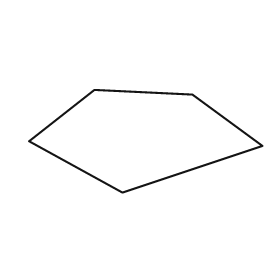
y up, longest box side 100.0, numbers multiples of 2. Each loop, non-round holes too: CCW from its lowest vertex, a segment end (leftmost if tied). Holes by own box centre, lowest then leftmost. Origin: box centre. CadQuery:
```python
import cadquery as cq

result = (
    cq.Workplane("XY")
    .moveTo(-10.0, -22.0)
    .lineTo(50.0, -2.0)
    .lineTo(20.0, 20.0)
    .lineTo(-22.0, 22.0)
    .lineTo(-50.0, 0.0)
    .close()
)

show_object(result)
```